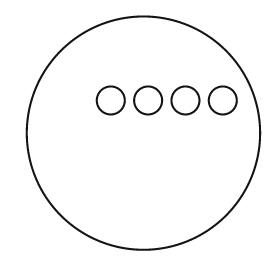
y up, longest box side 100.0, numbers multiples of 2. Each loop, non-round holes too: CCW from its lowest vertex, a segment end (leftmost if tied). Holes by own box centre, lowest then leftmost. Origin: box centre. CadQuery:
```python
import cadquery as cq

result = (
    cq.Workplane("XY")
    .moveTo(0.0, 0.0)
    .circle(50.0)
    .moveTo(-14.0, 14.0)
    .circle(6.0)
    .moveTo(2.0, 14.0)
    .circle(6.0)
    .moveTo(18.0, 14.0)
    .circle(6.0)
    .moveTo(34.0, 14.0)
    .circle(6.0)
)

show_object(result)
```